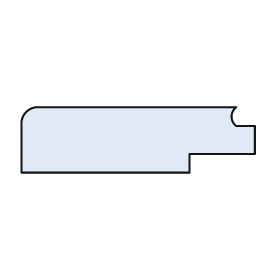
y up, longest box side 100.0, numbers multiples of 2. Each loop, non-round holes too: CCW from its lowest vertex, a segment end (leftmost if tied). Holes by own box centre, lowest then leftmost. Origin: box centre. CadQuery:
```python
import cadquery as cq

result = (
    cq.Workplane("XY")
    .moveTo(-50.0, -14.0)
    .lineTo(22.0, -14.0)
    .lineTo(22.0, -6.0)
    .lineTo(50.0, -6.0)
    .lineTo(50.0, 6.0)
    .lineTo(42.0, 6.0)
    .threePointArc((40.0, 10.0), (42.0, 14.0))
    .lineTo(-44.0, 14.0)
    .threePointArc((-48.0, 12.0), (-50.0, 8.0))
    .close()
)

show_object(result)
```